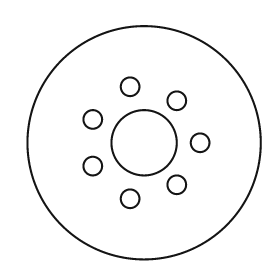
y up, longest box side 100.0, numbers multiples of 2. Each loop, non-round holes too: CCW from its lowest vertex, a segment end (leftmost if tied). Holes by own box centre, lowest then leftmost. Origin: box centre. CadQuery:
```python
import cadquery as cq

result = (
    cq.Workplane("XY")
    .moveTo(0.0, 0.0)
    .circle(50.0)
    .moveTo(-6.0, -24.0)
    .circle(4.0)
    .moveTo(14.0, -18.0)
    .circle(4.0)
    .moveTo(-22.0, -10.0)
    .circle(4.0)
    .moveTo(0.0, 0.0)
    .circle(14.0)
    .moveTo(24.0, 0.0)
    .circle(4.0)
    .moveTo(-22.0, 10.0)
    .circle(4.0)
    .moveTo(14.0, 18.0)
    .circle(4.0)
    .moveTo(-6.0, 24.0)
    .circle(4.0)
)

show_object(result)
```